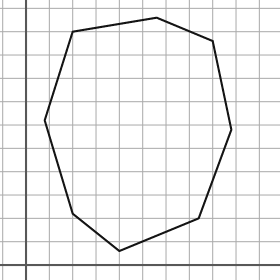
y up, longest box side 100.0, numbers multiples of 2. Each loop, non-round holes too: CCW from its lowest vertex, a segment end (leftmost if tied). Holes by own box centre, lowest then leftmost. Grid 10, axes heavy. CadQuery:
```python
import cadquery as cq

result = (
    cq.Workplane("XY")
    .moveTo(40.0, 6.0)
    .lineTo(74.0, 20.0)
    .lineTo(88.0, 58.0)
    .lineTo(80.0, 96.0)
    .lineTo(56.0, 106.0)
    .lineTo(20.0, 100.0)
    .lineTo(8.0, 62.0)
    .lineTo(20.0, 22.0)
    .close()
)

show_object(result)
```